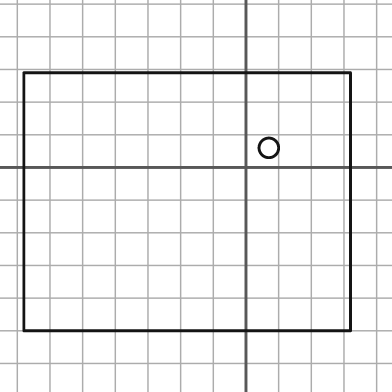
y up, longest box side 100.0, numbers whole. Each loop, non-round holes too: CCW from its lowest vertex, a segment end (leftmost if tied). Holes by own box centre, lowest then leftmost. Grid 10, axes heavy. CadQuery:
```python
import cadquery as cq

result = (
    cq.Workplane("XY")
    .moveTo(-68.0, -50.0)
    .lineTo(32.0, -50.0)
    .lineTo(32.0, 29.0)
    .lineTo(-68.0, 29.0)
    .close()
    .moveTo(7.0, 6.0)
    .circle(3.0)
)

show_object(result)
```